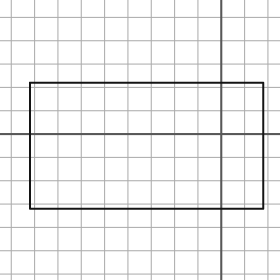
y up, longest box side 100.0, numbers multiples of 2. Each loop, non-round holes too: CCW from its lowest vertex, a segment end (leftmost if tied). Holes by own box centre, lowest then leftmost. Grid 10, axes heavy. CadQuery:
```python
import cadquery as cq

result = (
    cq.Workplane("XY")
    .moveTo(-82.0, -32.0)
    .lineTo(18.0, -32.0)
    .lineTo(18.0, 22.0)
    .lineTo(-82.0, 22.0)
    .close()
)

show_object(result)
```